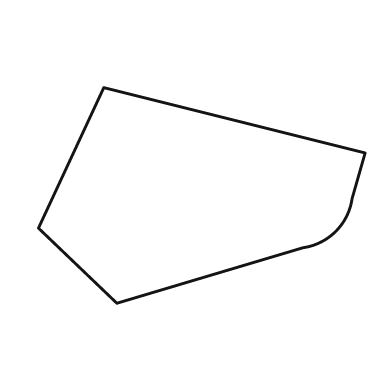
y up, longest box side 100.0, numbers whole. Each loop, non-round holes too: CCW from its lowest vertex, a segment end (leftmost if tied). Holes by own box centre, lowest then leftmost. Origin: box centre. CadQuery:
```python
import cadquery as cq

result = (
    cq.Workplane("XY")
    .moveTo(-26.0, -33.0)
    .lineTo(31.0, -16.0)
    .threePointArc((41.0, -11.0), (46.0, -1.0))
    .lineTo(50.0, 13.0)
    .lineTo(-30.0, 33.0)
    .lineTo(-50.0, -10.0)
    .close()
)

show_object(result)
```